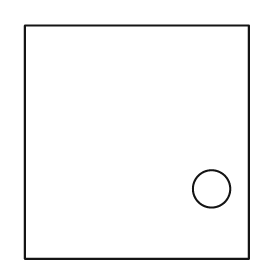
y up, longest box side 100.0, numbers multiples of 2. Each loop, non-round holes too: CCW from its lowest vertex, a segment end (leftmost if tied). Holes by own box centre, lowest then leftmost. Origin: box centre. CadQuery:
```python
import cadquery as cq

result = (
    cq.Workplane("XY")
    .moveTo(-48.0, -50.0)
    .lineTo(48.0, -50.0)
    .lineTo(48.0, 50.0)
    .lineTo(-48.0, 50.0)
    .close()
    .moveTo(32.0, -20.0)
    .circle(8.0)
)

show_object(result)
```